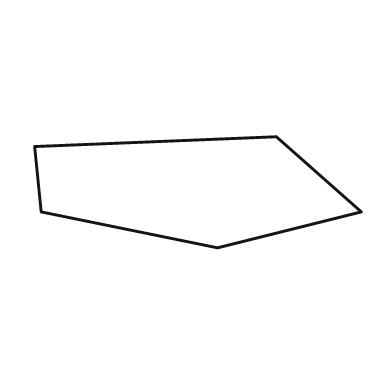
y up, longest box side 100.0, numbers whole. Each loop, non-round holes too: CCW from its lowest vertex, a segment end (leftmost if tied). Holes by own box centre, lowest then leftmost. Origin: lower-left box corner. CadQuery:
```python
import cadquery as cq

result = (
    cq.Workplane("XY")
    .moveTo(56.0, 0.0)
    .lineTo(100.0, 11.0)
    .lineTo(74.0, 34.0)
    .lineTo(0.0, 31.0)
    .lineTo(2.0, 11.0)
    .close()
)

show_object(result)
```